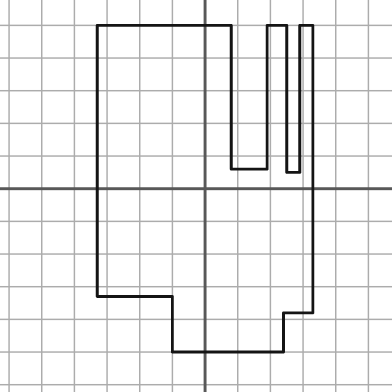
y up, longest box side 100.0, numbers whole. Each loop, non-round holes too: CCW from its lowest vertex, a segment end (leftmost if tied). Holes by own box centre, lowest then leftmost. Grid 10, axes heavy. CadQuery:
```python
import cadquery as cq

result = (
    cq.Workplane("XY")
    .moveTo(-10.0, -50.0)
    .lineTo(24.0, -50.0)
    .lineTo(24.0, -38.0)
    .lineTo(33.0, -38.0)
    .lineTo(33.0, 50.0)
    .lineTo(29.0, 50.0)
    .lineTo(29.0, 5.0)
    .lineTo(25.0, 5.0)
    .lineTo(25.0, 50.0)
    .lineTo(19.0, 50.0)
    .lineTo(19.0, 6.0)
    .lineTo(8.0, 6.0)
    .lineTo(8.0, 50.0)
    .lineTo(-33.0, 50.0)
    .lineTo(-33.0, -33.0)
    .lineTo(-10.0, -33.0)
    .close()
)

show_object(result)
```